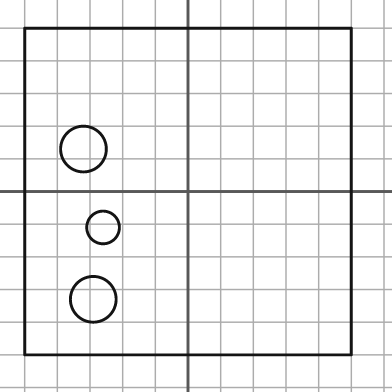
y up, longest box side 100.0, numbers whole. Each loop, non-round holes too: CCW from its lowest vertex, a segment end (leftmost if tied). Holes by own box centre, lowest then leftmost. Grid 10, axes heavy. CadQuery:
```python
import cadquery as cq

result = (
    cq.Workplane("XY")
    .moveTo(-50.0, -50.0)
    .lineTo(50.0, -50.0)
    .lineTo(50.0, 50.0)
    .lineTo(-50.0, 50.0)
    .close()
    .moveTo(-29.0, -33.0)
    .circle(7.0)
    .moveTo(-26.0, -11.0)
    .circle(5.0)
    .moveTo(-32.0, 13.0)
    .circle(7.0)
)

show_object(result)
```